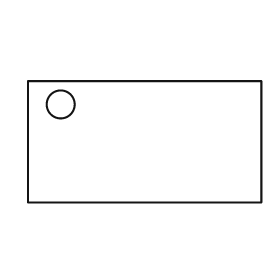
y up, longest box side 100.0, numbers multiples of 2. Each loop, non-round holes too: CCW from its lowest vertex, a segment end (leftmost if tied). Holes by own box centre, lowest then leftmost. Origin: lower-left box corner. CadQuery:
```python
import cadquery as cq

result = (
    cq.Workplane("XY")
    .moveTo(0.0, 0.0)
    .lineTo(100.0, 0.0)
    .lineTo(100.0, 52.0)
    .lineTo(0.0, 52.0)
    .close()
    .moveTo(14.0, 42.0)
    .circle(6.0)
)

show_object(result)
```